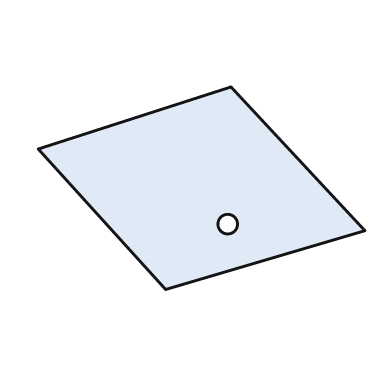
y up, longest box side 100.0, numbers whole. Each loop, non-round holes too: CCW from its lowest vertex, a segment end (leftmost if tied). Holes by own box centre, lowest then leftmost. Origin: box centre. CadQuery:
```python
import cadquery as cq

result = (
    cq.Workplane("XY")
    .moveTo(-11.0, -31.0)
    .lineTo(50.0, -13.0)
    .lineTo(9.0, 31.0)
    .lineTo(-50.0, 12.0)
    .close()
    .moveTo(8.0, -11.0)
    .circle(3.0)
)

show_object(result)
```